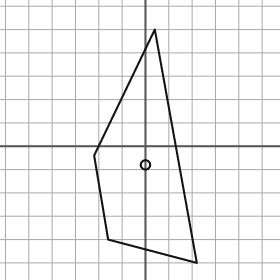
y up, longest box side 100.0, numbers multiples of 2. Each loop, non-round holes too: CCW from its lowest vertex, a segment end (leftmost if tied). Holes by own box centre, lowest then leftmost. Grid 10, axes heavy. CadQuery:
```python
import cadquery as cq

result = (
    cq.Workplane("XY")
    .moveTo(22.0, -50.0)
    .lineTo(4.0, 50.0)
    .lineTo(-22.0, -4.0)
    .lineTo(-16.0, -40.0)
    .close()
    .moveTo(0.0, -8.0)
    .circle(2.0)
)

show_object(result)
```